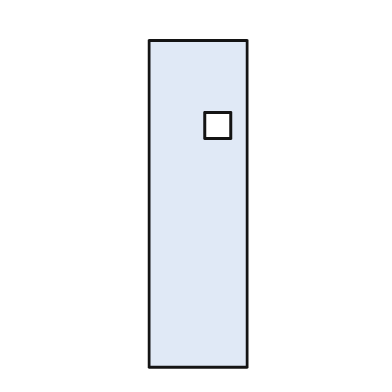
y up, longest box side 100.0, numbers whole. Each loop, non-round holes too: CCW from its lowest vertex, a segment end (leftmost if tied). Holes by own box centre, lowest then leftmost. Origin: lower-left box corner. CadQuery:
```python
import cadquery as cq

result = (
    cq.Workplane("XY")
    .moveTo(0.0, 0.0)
    .lineTo(30.0, 0.0)
    .lineTo(30.0, 100.0)
    .lineTo(0.0, 100.0)
    .close()
    .moveTo(17.0, 70.0)
    .lineTo(25.0, 70.0)
    .lineTo(25.0, 78.0)
    .lineTo(17.0, 78.0)
    .close()
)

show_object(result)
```